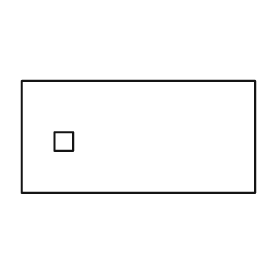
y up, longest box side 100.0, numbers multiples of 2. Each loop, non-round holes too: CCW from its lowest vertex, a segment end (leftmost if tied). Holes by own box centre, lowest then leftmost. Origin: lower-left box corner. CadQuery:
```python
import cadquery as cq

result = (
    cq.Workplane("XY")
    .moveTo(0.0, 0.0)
    .lineTo(100.0, 0.0)
    .lineTo(100.0, 48.0)
    .lineTo(0.0, 48.0)
    .close()
    .moveTo(14.0, 18.0)
    .lineTo(22.0, 18.0)
    .lineTo(22.0, 26.0)
    .lineTo(14.0, 26.0)
    .close()
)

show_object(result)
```